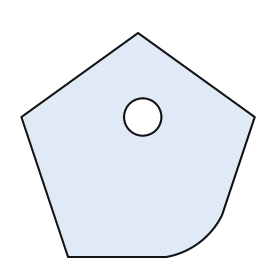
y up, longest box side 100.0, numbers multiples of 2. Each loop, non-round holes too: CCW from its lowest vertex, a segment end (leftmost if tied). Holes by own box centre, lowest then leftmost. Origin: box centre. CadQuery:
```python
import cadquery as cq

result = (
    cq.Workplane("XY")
    .moveTo(-30.0, -48.0)
    .lineTo(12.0, -48.0)
    .threePointArc((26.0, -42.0), (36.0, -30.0))
    .lineTo(50.0, 12.0)
    .lineTo(0.0, 48.0)
    .lineTo(-50.0, 12.0)
    .close()
    .moveTo(2.0, 12.0)
    .circle(8.0)
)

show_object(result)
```